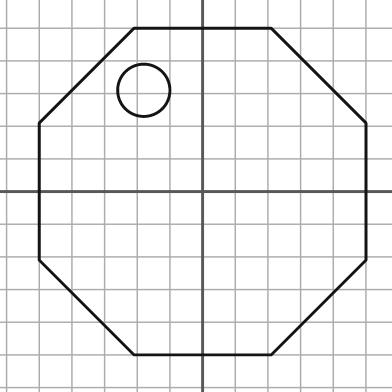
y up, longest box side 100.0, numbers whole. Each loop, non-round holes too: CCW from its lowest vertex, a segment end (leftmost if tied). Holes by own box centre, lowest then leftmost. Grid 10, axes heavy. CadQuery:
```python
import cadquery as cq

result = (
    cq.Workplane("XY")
    .moveTo(-21.0, -50.0)
    .lineTo(21.0, -50.0)
    .lineTo(50.0, -21.0)
    .lineTo(50.0, 21.0)
    .lineTo(21.0, 50.0)
    .lineTo(-21.0, 50.0)
    .lineTo(-50.0, 21.0)
    .lineTo(-50.0, -21.0)
    .close()
    .moveTo(-18.0, 31.0)
    .circle(8.0)
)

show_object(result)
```